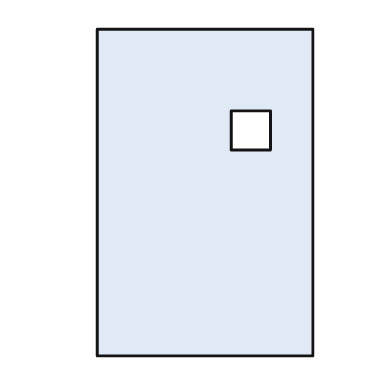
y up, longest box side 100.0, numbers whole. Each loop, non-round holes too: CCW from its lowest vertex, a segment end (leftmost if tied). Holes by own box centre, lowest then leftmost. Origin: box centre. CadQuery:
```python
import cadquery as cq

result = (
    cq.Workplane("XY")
    .moveTo(-33.0, -50.0)
    .lineTo(33.0, -50.0)
    .lineTo(33.0, 50.0)
    .lineTo(-33.0, 50.0)
    .close()
    .moveTo(8.0, 13.0)
    .lineTo(20.0, 13.0)
    .lineTo(20.0, 25.0)
    .lineTo(8.0, 25.0)
    .close()
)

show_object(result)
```